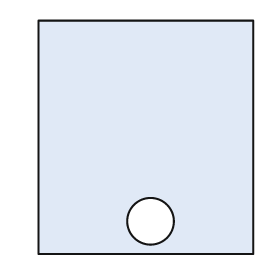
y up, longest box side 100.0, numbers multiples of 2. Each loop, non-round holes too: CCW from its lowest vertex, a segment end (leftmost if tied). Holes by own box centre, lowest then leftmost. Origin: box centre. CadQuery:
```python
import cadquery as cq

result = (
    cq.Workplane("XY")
    .moveTo(-46.0, -50.0)
    .lineTo(46.0, -50.0)
    .lineTo(46.0, 50.0)
    .lineTo(-46.0, 50.0)
    .close()
    .moveTo(2.0, -36.0)
    .circle(10.0)
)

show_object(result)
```